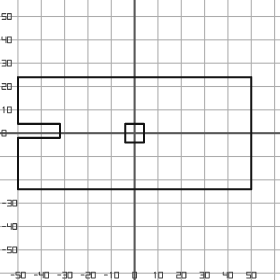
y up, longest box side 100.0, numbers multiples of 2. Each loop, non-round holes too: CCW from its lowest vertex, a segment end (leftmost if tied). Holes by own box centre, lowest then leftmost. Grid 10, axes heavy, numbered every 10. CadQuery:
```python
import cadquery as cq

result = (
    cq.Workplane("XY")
    .moveTo(-50.0, -24.0)
    .lineTo(50.0, -24.0)
    .lineTo(50.0, 24.0)
    .lineTo(-50.0, 24.0)
    .lineTo(-50.0, 4.0)
    .lineTo(-32.0, 4.0)
    .lineTo(-32.0, -2.0)
    .lineTo(-50.0, -2.0)
    .close()
    .moveTo(-4.0, -4.0)
    .lineTo(4.0, -4.0)
    .lineTo(4.0, 4.0)
    .lineTo(-4.0, 4.0)
    .close()
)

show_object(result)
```